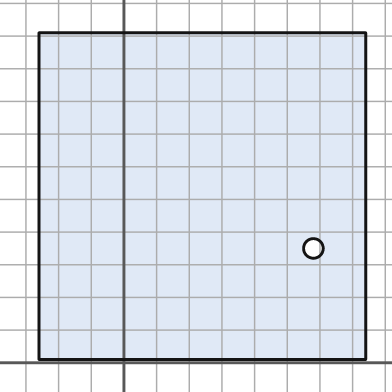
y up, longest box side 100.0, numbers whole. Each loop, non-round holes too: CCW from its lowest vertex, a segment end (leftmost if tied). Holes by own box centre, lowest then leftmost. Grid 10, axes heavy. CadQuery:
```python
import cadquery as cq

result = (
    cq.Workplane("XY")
    .moveTo(-26.0, 1.0)
    .lineTo(74.0, 1.0)
    .lineTo(74.0, 101.0)
    .lineTo(-26.0, 101.0)
    .close()
    .moveTo(58.0, 35.0)
    .circle(3.0)
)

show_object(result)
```